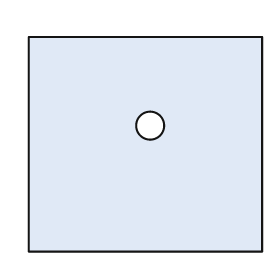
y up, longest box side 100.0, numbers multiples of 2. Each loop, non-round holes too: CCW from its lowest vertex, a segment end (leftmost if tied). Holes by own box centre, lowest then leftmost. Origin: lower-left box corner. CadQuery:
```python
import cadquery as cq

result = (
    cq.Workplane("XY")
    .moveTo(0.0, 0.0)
    .lineTo(100.0, 0.0)
    .lineTo(100.0, 92.0)
    .lineTo(0.0, 92.0)
    .close()
    .moveTo(52.0, 54.0)
    .circle(6.0)
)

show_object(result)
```